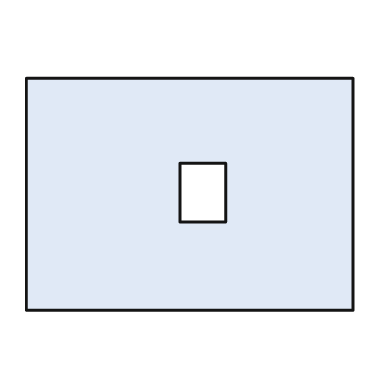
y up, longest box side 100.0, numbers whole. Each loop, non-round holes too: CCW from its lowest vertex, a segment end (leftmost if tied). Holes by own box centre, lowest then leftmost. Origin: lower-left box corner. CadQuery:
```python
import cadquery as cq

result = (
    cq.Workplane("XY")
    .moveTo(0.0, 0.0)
    .lineTo(100.0, 0.0)
    .lineTo(100.0, 71.0)
    .lineTo(0.0, 71.0)
    .close()
    .moveTo(47.0, 27.0)
    .lineTo(61.0, 27.0)
    .lineTo(61.0, 45.0)
    .lineTo(47.0, 45.0)
    .close()
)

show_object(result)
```